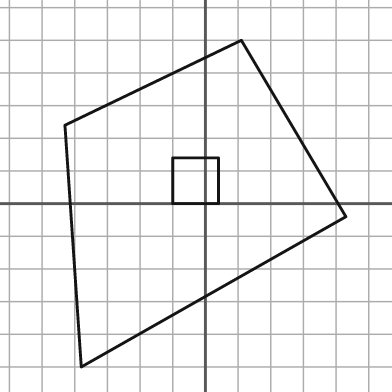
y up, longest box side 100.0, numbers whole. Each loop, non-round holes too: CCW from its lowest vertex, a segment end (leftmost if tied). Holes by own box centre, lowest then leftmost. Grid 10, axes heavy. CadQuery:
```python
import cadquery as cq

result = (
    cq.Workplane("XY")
    .moveTo(-38.0, -50.0)
    .lineTo(43.0, -4.0)
    .lineTo(11.0, 50.0)
    .lineTo(-43.0, 24.0)
    .close()
    .moveTo(-10.0, 0.0)
    .lineTo(4.0, 0.0)
    .lineTo(4.0, 14.0)
    .lineTo(-10.0, 14.0)
    .close()
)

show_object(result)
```